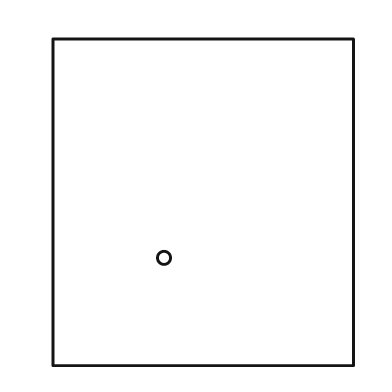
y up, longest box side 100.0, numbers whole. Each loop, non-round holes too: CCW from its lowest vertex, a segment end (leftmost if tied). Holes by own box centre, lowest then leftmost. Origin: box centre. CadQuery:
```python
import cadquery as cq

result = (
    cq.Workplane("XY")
    .moveTo(-46.0, -50.0)
    .lineTo(46.0, -50.0)
    .lineTo(46.0, 50.0)
    .lineTo(-46.0, 50.0)
    .close()
    .moveTo(-12.0, -17.0)
    .circle(2.0)
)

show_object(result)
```